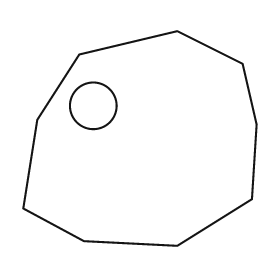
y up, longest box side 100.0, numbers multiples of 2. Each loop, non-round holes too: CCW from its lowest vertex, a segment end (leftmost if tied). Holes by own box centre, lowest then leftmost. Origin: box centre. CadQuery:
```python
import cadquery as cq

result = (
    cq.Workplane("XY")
    .moveTo(16.0, -46.0)
    .lineTo(48.0, -26.0)
    .lineTo(50.0, 6.0)
    .lineTo(44.0, 32.0)
    .lineTo(16.0, 46.0)
    .lineTo(-26.0, 36.0)
    .lineTo(-44.0, 8.0)
    .lineTo(-50.0, -30.0)
    .lineTo(-24.0, -44.0)
    .close()
    .moveTo(-20.0, 14.0)
    .circle(10.0)
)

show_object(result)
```